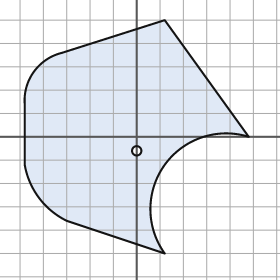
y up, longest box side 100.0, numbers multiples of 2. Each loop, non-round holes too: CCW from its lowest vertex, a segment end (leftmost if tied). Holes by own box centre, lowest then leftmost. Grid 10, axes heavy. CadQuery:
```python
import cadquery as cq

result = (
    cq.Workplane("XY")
    .moveTo(12.0, -50.0)
    .threePointArc((12.0, -12.0), (48.0, 0.0))
    .lineTo(12.0, 50.0)
    .lineTo(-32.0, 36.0)
    .threePointArc((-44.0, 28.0), (-48.0, 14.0))
    .lineTo(-48.0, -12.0)
    .threePointArc((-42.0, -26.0), (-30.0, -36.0))
    .close()
    .moveTo(0.0, -6.0)
    .circle(2.0)
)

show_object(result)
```